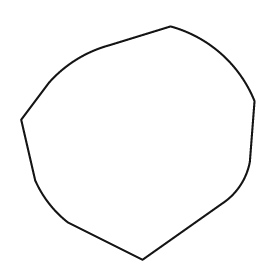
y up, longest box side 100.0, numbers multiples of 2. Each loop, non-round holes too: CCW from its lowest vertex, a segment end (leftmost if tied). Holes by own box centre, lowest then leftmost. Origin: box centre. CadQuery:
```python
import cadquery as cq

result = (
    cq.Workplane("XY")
    .moveTo(2.0, -50.0)
    .lineTo(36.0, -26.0)
    .threePointArc((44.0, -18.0), (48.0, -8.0))
    .lineTo(50.0, 18.0)
    .threePointArc((36.0, 38.0), (14.0, 50.0))
    .lineTo(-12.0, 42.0)
    .threePointArc((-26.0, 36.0), (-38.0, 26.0))
    .lineTo(-50.0, 10.0)
    .lineTo(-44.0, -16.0)
    .threePointArc((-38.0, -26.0), (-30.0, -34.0))
    .close()
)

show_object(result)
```